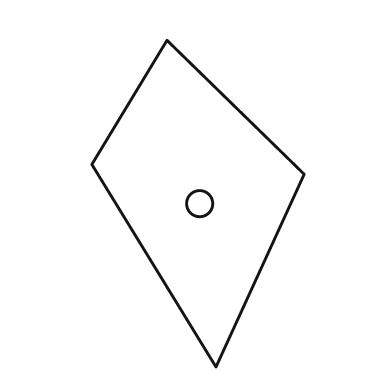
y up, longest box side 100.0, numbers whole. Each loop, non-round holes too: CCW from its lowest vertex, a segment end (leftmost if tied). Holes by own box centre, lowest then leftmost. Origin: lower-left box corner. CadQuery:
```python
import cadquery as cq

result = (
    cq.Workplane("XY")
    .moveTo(38.0, 0.0)
    .lineTo(65.0, 59.0)
    .lineTo(23.0, 100.0)
    .lineTo(0.0, 62.0)
    .close()
    .moveTo(33.0, 50.0)
    .circle(4.0)
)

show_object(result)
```